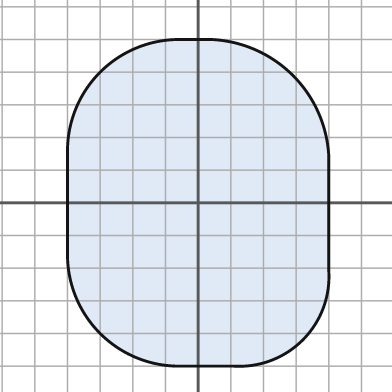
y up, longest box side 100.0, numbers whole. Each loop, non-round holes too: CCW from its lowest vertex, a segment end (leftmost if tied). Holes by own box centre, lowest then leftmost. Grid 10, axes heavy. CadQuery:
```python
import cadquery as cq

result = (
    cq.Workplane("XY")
    .moveTo(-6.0, -50.0)
    .lineTo(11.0, -50.0)
    .threePointArc((32.0, -42.0), (40.0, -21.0))
    .lineTo(40.0, 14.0)
    .threePointArc((29.0, 39.0), (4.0, 50.0))
    .lineTo(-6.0, 50.0)
    .threePointArc((-30.0, 40.0), (-40.0, 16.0))
    .lineTo(-40.0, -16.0)
    .threePointArc((-30.0, -40.0), (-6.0, -50.0))
    .close()
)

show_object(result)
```